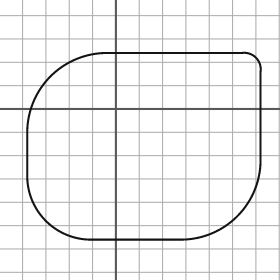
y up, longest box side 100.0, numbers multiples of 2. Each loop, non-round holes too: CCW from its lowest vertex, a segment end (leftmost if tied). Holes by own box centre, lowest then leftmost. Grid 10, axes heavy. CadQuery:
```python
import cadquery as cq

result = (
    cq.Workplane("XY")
    .moveTo(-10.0, -56.0)
    .lineTo(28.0, -56.0)
    .threePointArc((52.0, -46.0), (62.0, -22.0))
    .lineTo(62.0, 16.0)
    .threePointArc((60.0, 22.0), (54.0, 24.0))
    .lineTo(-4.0, 24.0)
    .threePointArc((-28.0, 14.0), (-38.0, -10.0))
    .lineTo(-38.0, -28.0)
    .threePointArc((-30.0, -48.0), (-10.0, -56.0))
    .close()
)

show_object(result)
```